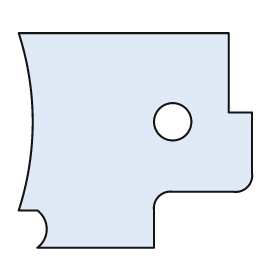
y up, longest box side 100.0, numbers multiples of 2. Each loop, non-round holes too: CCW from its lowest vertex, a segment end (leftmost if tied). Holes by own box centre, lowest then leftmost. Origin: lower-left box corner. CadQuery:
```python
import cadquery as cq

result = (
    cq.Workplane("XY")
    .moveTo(8.0, 0.0)
    .lineTo(58.0, 0.0)
    .lineTo(58.0, 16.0)
    .threePointArc((60.0, 22.0), (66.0, 24.0))
    .lineTo(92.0, 24.0)
    .threePointArc((98.0, 26.0), (100.0, 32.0))
    .lineTo(100.0, 58.0)
    .lineTo(90.0, 58.0)
    .lineTo(90.0, 92.0)
    .lineTo(0.0, 92.0)
    .threePointArc((6.0, 54.0), (0.0, 16.0))
    .lineTo(8.0, 16.0)
    .threePointArc((12.0, 8.0), (8.0, 0.0))
    .close()
    .moveTo(66.0, 54.0)
    .circle(8.0)
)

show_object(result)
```